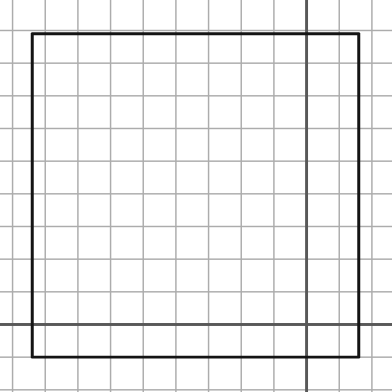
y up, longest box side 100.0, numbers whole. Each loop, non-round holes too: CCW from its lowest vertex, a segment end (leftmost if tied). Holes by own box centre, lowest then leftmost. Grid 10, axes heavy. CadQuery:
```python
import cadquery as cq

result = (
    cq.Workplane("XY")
    .moveTo(-84.0, -10.0)
    .lineTo(16.0, -10.0)
    .lineTo(16.0, 89.0)
    .lineTo(-84.0, 89.0)
    .close()
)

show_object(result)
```